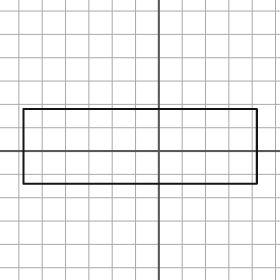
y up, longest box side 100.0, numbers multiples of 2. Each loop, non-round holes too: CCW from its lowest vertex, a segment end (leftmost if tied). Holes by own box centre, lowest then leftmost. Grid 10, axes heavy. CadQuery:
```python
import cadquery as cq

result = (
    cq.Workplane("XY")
    .moveTo(-58.0, -14.0)
    .lineTo(42.0, -14.0)
    .lineTo(42.0, 18.0)
    .lineTo(-58.0, 18.0)
    .close()
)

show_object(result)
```